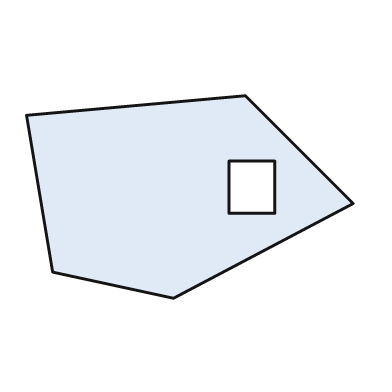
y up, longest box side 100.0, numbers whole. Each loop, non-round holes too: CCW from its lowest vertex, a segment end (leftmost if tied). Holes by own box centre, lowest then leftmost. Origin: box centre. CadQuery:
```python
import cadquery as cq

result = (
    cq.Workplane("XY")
    .moveTo(-5.0, -31.0)
    .lineTo(50.0, -2.0)
    .lineTo(17.0, 31.0)
    .lineTo(-50.0, 25.0)
    .lineTo(-42.0, -23.0)
    .close()
    .moveTo(12.0, -5.0)
    .lineTo(26.0, -5.0)
    .lineTo(26.0, 11.0)
    .lineTo(12.0, 11.0)
    .close()
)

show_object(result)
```